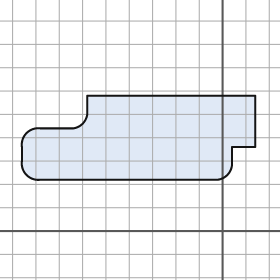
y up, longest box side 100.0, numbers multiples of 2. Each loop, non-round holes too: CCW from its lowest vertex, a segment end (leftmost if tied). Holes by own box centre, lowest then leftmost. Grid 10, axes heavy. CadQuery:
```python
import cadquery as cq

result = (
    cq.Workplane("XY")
    .moveTo(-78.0, 22.0)
    .lineTo(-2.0, 22.0)
    .threePointArc((2.0, 24.0), (4.0, 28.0))
    .lineTo(4.0, 36.0)
    .lineTo(14.0, 36.0)
    .lineTo(14.0, 58.0)
    .lineTo(-58.0, 58.0)
    .lineTo(-58.0, 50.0)
    .threePointArc((-60.0, 46.0), (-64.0, 44.0))
    .lineTo(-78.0, 44.0)
    .threePointArc((-84.0, 42.0), (-86.0, 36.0))
    .lineTo(-86.0, 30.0)
    .threePointArc((-84.0, 24.0), (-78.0, 22.0))
    .close()
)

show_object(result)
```